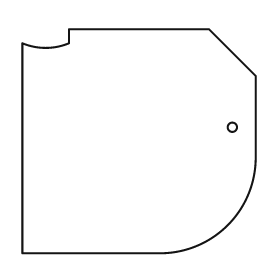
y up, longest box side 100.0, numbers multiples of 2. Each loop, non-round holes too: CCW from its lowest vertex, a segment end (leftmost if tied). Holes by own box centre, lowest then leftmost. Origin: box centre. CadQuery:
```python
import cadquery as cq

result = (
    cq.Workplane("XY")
    .moveTo(-50.0, -48.0)
    .lineTo(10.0, -48.0)
    .threePointArc((38.0, -36.0), (50.0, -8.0))
    .lineTo(50.0, 28.0)
    .lineTo(30.0, 48.0)
    .lineTo(-30.0, 48.0)
    .lineTo(-30.0, 42.0)
    .threePointArc((-40.0, 40.0), (-50.0, 42.0))
    .close()
    .moveTo(40.0, 6.0)
    .circle(2.0)
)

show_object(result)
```